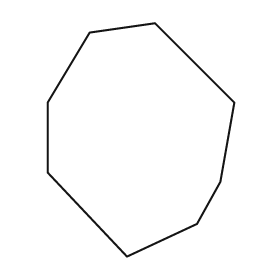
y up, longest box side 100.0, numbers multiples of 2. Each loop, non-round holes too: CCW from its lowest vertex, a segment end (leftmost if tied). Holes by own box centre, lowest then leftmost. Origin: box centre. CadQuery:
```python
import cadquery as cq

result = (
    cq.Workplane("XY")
    .moveTo(-6.0, -50.0)
    .lineTo(24.0, -36.0)
    .lineTo(34.0, -18.0)
    .lineTo(40.0, 16.0)
    .lineTo(6.0, 50.0)
    .lineTo(-22.0, 46.0)
    .lineTo(-40.0, 16.0)
    .lineTo(-40.0, -14.0)
    .close()
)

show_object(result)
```